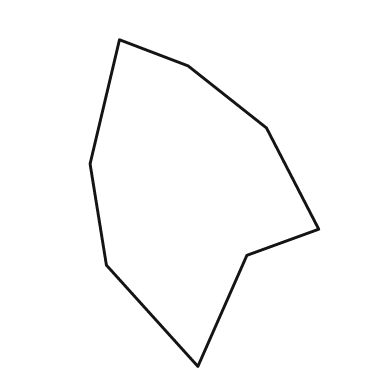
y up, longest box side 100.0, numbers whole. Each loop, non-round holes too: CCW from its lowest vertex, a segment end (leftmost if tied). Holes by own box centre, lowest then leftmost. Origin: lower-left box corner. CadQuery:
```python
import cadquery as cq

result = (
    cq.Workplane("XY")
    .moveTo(33.0, 0.0)
    .lineTo(48.0, 34.0)
    .lineTo(70.0, 42.0)
    .lineTo(54.0, 73.0)
    .lineTo(30.0, 92.0)
    .lineTo(9.0, 100.0)
    .lineTo(0.0, 62.0)
    .lineTo(5.0, 31.0)
    .close()
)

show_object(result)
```